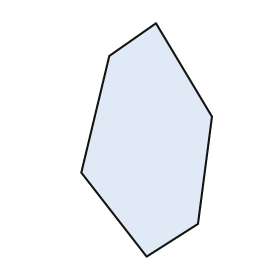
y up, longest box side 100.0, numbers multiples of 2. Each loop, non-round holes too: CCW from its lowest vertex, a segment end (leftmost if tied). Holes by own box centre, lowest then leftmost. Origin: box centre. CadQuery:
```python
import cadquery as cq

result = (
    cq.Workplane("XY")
    .moveTo(0.0, -50.0)
    .lineTo(22.0, -36.0)
    .lineTo(28.0, 10.0)
    .lineTo(4.0, 50.0)
    .lineTo(-16.0, 36.0)
    .lineTo(-28.0, -14.0)
    .close()
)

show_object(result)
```